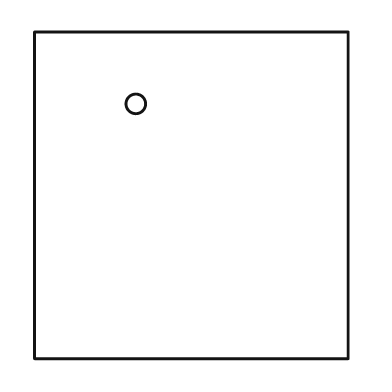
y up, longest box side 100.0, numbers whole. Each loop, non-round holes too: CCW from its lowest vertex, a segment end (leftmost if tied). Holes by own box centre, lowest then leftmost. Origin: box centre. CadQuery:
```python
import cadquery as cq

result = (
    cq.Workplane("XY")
    .moveTo(-48.0, -50.0)
    .lineTo(48.0, -50.0)
    .lineTo(48.0, 50.0)
    .lineTo(-48.0, 50.0)
    .close()
    .moveTo(-17.0, 28.0)
    .circle(3.0)
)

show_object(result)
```